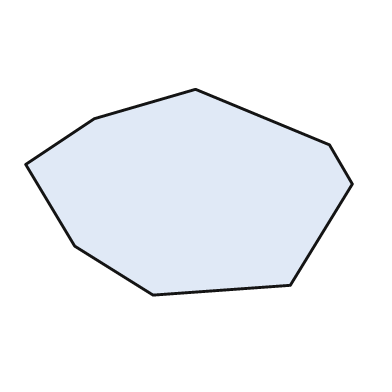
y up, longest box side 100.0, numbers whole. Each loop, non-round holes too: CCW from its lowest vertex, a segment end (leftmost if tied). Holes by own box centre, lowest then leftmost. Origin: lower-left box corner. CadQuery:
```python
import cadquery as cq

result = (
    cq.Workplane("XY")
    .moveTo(39.0, 0.0)
    .lineTo(81.0, 3.0)
    .lineTo(100.0, 34.0)
    .lineTo(93.0, 46.0)
    .lineTo(52.0, 63.0)
    .lineTo(21.0, 54.0)
    .lineTo(0.0, 40.0)
    .lineTo(15.0, 15.0)
    .close()
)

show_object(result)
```